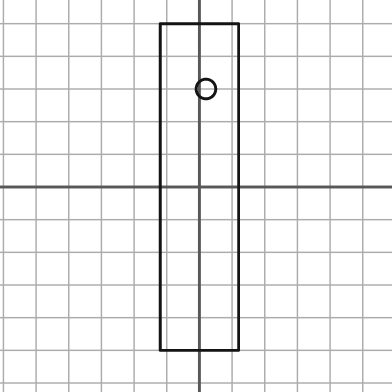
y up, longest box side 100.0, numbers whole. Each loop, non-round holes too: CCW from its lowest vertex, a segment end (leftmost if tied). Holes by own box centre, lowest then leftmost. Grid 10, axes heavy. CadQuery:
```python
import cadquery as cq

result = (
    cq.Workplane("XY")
    .moveTo(-12.0, -50.0)
    .lineTo(12.0, -50.0)
    .lineTo(12.0, 50.0)
    .lineTo(-12.0, 50.0)
    .close()
    .moveTo(2.0, 30.0)
    .circle(3.0)
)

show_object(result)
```